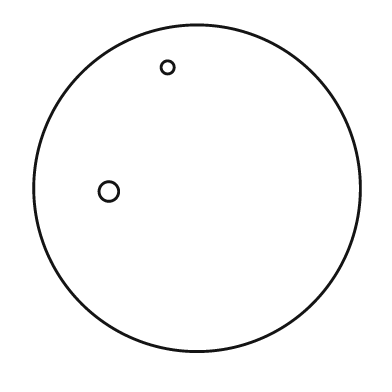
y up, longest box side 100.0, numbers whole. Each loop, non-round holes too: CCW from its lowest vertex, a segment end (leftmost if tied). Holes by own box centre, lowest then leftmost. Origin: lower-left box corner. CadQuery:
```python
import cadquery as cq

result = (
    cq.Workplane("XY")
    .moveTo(50.0, 50.0)
    .circle(50.0)
    .moveTo(23.0, 49.0)
    .circle(3.0)
    .moveTo(41.0, 87.0)
    .circle(2.0)
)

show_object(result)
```